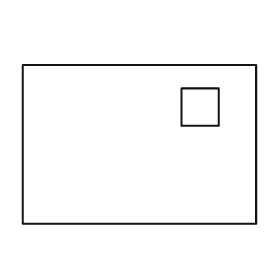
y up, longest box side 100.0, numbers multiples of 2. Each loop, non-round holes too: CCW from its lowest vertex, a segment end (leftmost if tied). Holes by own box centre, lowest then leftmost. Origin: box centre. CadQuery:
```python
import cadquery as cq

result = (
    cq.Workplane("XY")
    .moveTo(-50.0, -34.0)
    .lineTo(50.0, -34.0)
    .lineTo(50.0, 34.0)
    .lineTo(-50.0, 34.0)
    .close()
    .moveTo(18.0, 8.0)
    .lineTo(34.0, 8.0)
    .lineTo(34.0, 24.0)
    .lineTo(18.0, 24.0)
    .close()
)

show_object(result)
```